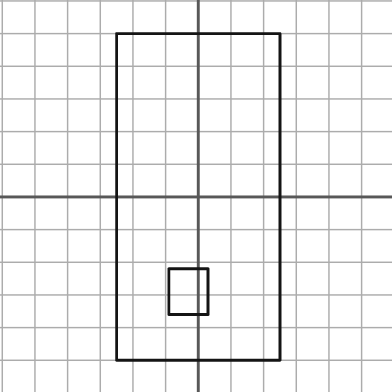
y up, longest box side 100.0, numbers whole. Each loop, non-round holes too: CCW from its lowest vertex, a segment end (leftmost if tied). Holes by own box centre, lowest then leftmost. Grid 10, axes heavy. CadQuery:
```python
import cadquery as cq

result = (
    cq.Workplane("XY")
    .moveTo(-25.0, -50.0)
    .lineTo(25.0, -50.0)
    .lineTo(25.0, 50.0)
    .lineTo(-25.0, 50.0)
    .close()
    .moveTo(-9.0, -36.0)
    .lineTo(3.0, -36.0)
    .lineTo(3.0, -22.0)
    .lineTo(-9.0, -22.0)
    .close()
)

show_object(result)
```